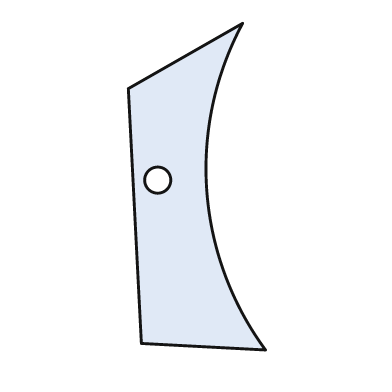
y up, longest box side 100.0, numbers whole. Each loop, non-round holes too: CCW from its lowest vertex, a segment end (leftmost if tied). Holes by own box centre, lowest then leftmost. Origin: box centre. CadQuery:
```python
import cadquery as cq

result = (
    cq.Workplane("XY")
    .moveTo(21.0, -50.0)
    .threePointArc((3.0, -1.0), (14.0, 50.0))
    .lineTo(-21.0, 30.0)
    .lineTo(-17.0, -48.0)
    .close()
    .moveTo(-12.0, 2.0)
    .circle(4.0)
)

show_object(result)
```